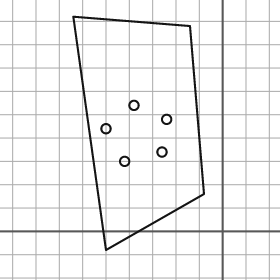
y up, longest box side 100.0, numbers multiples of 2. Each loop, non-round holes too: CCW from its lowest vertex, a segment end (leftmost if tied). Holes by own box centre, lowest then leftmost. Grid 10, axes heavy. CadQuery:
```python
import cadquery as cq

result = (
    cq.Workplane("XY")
    .moveTo(-50.0, -8.0)
    .lineTo(-8.0, 16.0)
    .lineTo(-14.0, 88.0)
    .lineTo(-64.0, 92.0)
    .close()
    .moveTo(-42.0, 30.0)
    .circle(2.0)
    .moveTo(-26.0, 34.0)
    .circle(2.0)
    .moveTo(-50.0, 44.0)
    .circle(2.0)
    .moveTo(-24.0, 48.0)
    .circle(2.0)
    .moveTo(-38.0, 54.0)
    .circle(2.0)
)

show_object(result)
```